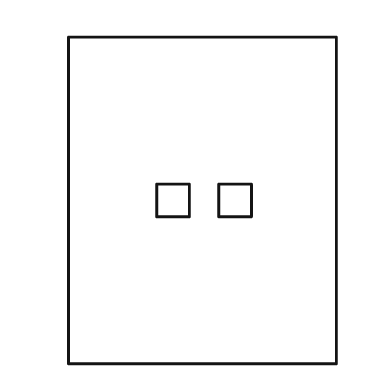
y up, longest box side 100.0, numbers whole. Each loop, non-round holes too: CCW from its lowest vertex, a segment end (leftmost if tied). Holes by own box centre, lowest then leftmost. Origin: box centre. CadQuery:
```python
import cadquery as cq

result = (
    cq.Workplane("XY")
    .moveTo(-41.0, -50.0)
    .lineTo(41.0, -50.0)
    .lineTo(41.0, 50.0)
    .lineTo(-41.0, 50.0)
    .close()
    .moveTo(-14.0, -5.0)
    .lineTo(-4.0, -5.0)
    .lineTo(-4.0, 5.0)
    .lineTo(-14.0, 5.0)
    .close()
    .moveTo(5.0, -5.0)
    .lineTo(15.0, -5.0)
    .lineTo(15.0, 5.0)
    .lineTo(5.0, 5.0)
    .close()
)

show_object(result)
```